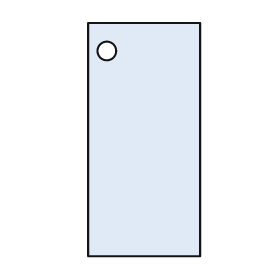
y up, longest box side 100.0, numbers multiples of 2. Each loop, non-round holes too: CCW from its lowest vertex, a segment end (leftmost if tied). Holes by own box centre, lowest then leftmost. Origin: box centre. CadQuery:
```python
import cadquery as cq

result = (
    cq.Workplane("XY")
    .moveTo(-24.0, -50.0)
    .lineTo(24.0, -50.0)
    .lineTo(24.0, 50.0)
    .lineTo(-24.0, 50.0)
    .close()
    .moveTo(-16.0, 38.0)
    .circle(4.0)
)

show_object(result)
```